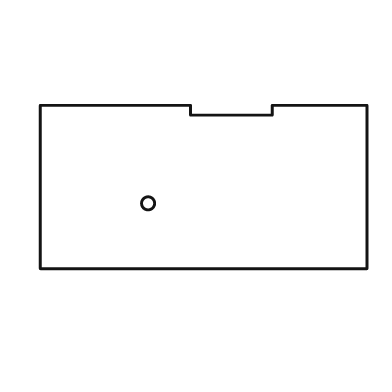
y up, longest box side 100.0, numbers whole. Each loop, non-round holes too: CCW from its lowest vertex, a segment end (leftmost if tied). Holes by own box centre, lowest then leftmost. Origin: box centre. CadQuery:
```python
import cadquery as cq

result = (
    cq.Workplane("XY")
    .moveTo(-50.0, -25.0)
    .lineTo(50.0, -25.0)
    .lineTo(50.0, 25.0)
    .lineTo(21.0, 25.0)
    .lineTo(21.0, 22.0)
    .lineTo(-4.0, 22.0)
    .lineTo(-4.0, 25.0)
    .lineTo(-50.0, 25.0)
    .close()
    .moveTo(-17.0, -5.0)
    .circle(2.0)
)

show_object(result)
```